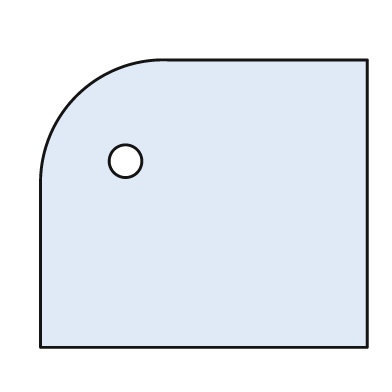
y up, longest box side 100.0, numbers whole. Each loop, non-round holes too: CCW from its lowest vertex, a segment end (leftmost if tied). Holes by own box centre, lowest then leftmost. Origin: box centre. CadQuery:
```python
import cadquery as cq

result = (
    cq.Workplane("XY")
    .moveTo(-50.0, -44.0)
    .lineTo(50.0, -44.0)
    .lineTo(50.0, 44.0)
    .lineTo(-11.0, 44.0)
    .threePointArc((-39.0, 33.0), (-50.0, 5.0))
    .close()
    .moveTo(-24.0, 13.0)
    .circle(5.0)
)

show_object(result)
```